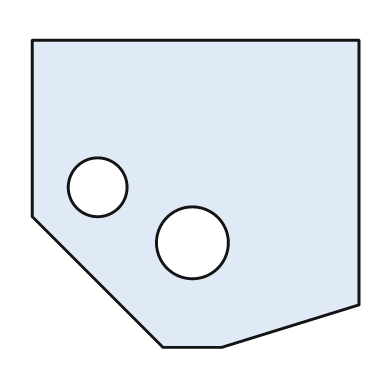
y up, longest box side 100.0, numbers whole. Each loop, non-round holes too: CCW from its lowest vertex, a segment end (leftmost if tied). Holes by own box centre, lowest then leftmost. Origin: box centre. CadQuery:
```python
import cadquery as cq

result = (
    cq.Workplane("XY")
    .moveTo(-10.0, -47.0)
    .lineTo(8.0, -47.0)
    .lineTo(50.0, -34.0)
    .lineTo(50.0, 47.0)
    .lineTo(-50.0, 47.0)
    .lineTo(-50.0, -7.0)
    .close()
    .moveTo(-1.0, -15.0)
    .circle(11.0)
    .moveTo(-30.0, 2.0)
    .circle(9.0)
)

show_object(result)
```